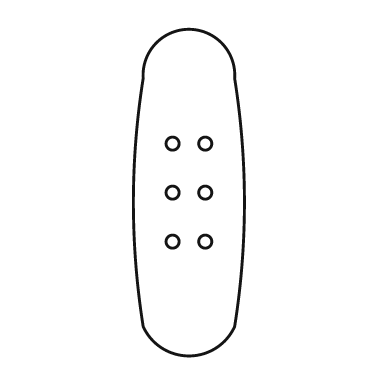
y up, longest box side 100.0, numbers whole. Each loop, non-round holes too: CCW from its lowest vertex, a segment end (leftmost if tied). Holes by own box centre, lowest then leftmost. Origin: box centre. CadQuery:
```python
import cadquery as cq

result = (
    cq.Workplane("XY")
    .moveTo(-14.0, -41.0)
    .threePointArc((0.0, -50.0), (14.0, -41.0))
    .threePointArc((17.0, -3.0), (14.0, 35.0))
    .threePointArc((0.0, 50.0), (-14.0, 35.0))
    .threePointArc((-17.0, -3.0), (-14.0, -41.0))
    .close()
    .moveTo(-5.0, -15.0)
    .circle(2.0)
    .moveTo(5.0, -15.0)
    .circle(2.0)
    .moveTo(-5.0, 0.0)
    .circle(2.0)
    .moveTo(5.0, 0.0)
    .circle(2.0)
    .moveTo(-5.0, 15.0)
    .circle(2.0)
    .moveTo(5.0, 15.0)
    .circle(2.0)
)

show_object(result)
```